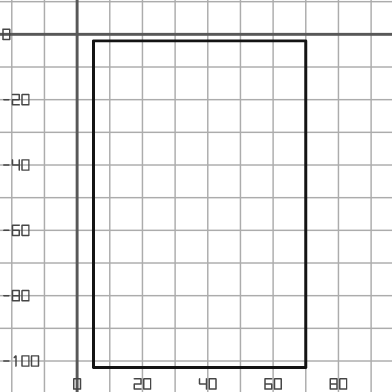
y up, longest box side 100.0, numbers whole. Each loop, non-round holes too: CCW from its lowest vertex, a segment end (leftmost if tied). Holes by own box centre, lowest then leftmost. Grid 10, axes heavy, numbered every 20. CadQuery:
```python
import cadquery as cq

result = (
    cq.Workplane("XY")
    .moveTo(5.0, -102.0)
    .lineTo(70.0, -102.0)
    .lineTo(70.0, -2.0)
    .lineTo(5.0, -2.0)
    .close()
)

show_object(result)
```